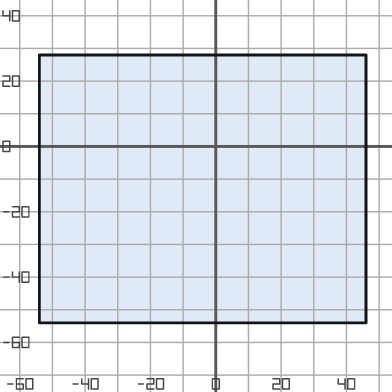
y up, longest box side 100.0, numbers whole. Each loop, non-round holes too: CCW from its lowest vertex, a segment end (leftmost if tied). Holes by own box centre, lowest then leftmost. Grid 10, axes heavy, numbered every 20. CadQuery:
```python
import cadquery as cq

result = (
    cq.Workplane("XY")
    .moveTo(-54.0, -54.0)
    .lineTo(46.0, -54.0)
    .lineTo(46.0, 28.0)
    .lineTo(-54.0, 28.0)
    .close()
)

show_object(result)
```